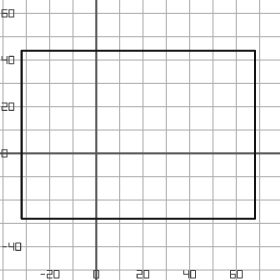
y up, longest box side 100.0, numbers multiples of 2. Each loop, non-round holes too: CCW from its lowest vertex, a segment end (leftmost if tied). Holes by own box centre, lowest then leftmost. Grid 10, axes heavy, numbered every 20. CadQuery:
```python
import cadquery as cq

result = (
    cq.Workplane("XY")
    .moveTo(-32.0, -28.0)
    .lineTo(68.0, -28.0)
    .lineTo(68.0, 44.0)
    .lineTo(-32.0, 44.0)
    .close()
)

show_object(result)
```